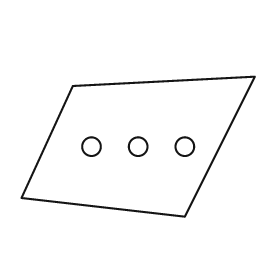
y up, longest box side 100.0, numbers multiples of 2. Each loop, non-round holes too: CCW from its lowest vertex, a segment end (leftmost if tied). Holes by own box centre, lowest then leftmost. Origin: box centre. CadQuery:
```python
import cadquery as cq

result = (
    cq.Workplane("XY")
    .moveTo(20.0, -30.0)
    .lineTo(50.0, 30.0)
    .lineTo(-28.0, 26.0)
    .lineTo(-50.0, -22.0)
    .close()
    .moveTo(-20.0, 0.0)
    .circle(4.0)
    .moveTo(0.0, 0.0)
    .circle(4.0)
    .moveTo(20.0, 0.0)
    .circle(4.0)
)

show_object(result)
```